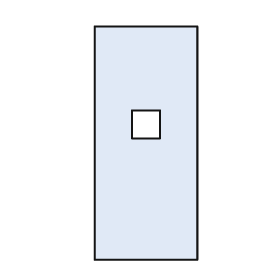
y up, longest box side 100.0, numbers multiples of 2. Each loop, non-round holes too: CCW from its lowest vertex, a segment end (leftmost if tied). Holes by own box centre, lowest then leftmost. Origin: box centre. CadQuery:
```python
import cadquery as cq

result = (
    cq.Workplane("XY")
    .moveTo(-22.0, -50.0)
    .lineTo(22.0, -50.0)
    .lineTo(22.0, 50.0)
    .lineTo(-22.0, 50.0)
    .close()
    .moveTo(-6.0, 2.0)
    .lineTo(6.0, 2.0)
    .lineTo(6.0, 14.0)
    .lineTo(-6.0, 14.0)
    .close()
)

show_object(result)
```